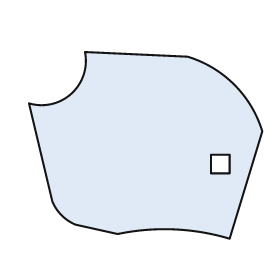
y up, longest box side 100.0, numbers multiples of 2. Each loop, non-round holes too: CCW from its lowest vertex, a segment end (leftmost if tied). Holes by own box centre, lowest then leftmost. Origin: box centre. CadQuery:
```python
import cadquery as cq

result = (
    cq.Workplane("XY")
    .moveTo(36.0, -40.0)
    .lineTo(50.0, 6.0)
    .threePointArc((38.0, 26.0), (18.0, 38.0))
    .lineTo(-26.0, 40.0)
    .threePointArc((-32.0, 22.0), (-50.0, 18.0))
    .lineTo(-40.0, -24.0)
    .threePointArc((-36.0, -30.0), (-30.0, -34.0))
    .lineTo(-12.0, -38.0)
    .threePointArc((12.0, -36.0), (36.0, -40.0))
    .close()
    .moveTo(28.0, -12.0)
    .lineTo(36.0, -12.0)
    .lineTo(36.0, -4.0)
    .lineTo(28.0, -4.0)
    .close()
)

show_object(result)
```